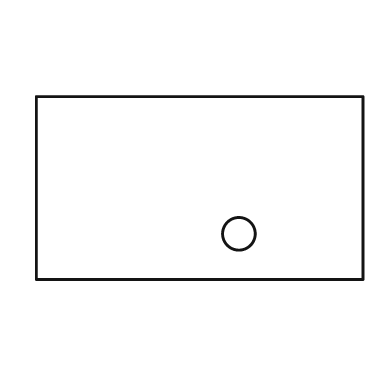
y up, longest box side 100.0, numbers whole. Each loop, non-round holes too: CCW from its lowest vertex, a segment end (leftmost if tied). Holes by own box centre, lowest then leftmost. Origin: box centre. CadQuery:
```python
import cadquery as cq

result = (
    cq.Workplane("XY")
    .moveTo(-50.0, -28.0)
    .lineTo(50.0, -28.0)
    .lineTo(50.0, 28.0)
    .lineTo(-50.0, 28.0)
    .close()
    .moveTo(12.0, -14.0)
    .circle(5.0)
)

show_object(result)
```